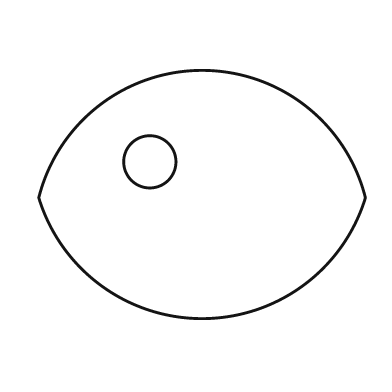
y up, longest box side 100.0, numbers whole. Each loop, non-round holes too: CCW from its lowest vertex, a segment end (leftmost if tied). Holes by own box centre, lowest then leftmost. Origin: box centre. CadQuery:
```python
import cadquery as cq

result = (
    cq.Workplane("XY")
    .moveTo(-50.0, -1.0)
    .threePointArc((0.0, -38.0), (50.0, -1.0))
    .threePointArc((0.0, 38.0), (-50.0, -1.0))
    .close()
    .moveTo(-16.0, 10.0)
    .circle(8.0)
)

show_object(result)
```